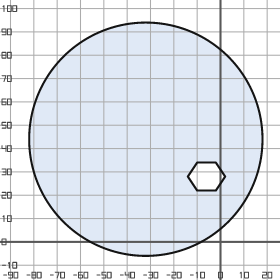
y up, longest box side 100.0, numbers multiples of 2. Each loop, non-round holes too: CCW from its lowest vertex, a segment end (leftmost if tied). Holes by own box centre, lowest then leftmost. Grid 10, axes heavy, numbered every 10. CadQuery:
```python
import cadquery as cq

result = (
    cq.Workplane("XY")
    .moveTo(-32.0, 44.0)
    .circle(50.0)
    .moveTo(-10.0, 22.0)
    .lineTo(-2.0, 22.0)
    .lineTo(2.0, 28.0)
    .lineTo(-2.0, 34.0)
    .lineTo(-10.0, 34.0)
    .lineTo(-14.0, 28.0)
    .close()
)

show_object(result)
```